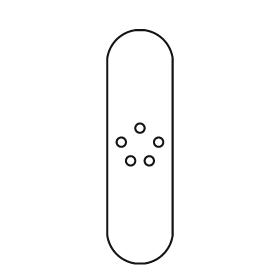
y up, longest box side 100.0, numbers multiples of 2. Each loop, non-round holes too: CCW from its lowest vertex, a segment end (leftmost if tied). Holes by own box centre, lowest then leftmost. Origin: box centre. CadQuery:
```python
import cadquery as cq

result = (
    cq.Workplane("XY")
    .moveTo(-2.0, -50.0)
    .lineTo(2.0, -50.0)
    .threePointArc((10.0, -46.0), (14.0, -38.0))
    .lineTo(14.0, 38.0)
    .threePointArc((10.0, 46.0), (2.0, 50.0))
    .lineTo(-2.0, 50.0)
    .threePointArc((-10.0, 46.0), (-14.0, 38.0))
    .lineTo(-14.0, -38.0)
    .threePointArc((-10.0, -46.0), (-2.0, -50.0))
    .close()
    .moveTo(-4.0, -6.0)
    .circle(2.0)
    .moveTo(4.0, -6.0)
    .circle(2.0)
    .moveTo(-8.0, 2.0)
    .circle(2.0)
    .moveTo(8.0, 2.0)
    .circle(2.0)
    .moveTo(0.0, 8.0)
    .circle(2.0)
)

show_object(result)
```